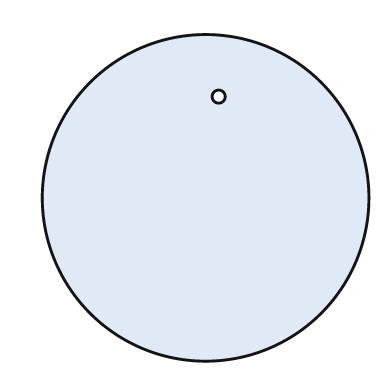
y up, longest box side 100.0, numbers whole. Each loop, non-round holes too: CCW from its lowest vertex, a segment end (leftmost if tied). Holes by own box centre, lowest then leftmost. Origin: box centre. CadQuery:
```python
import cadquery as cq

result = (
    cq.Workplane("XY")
    .moveTo(0.0, 0.0)
    .circle(50.0)
    .moveTo(4.0, 31.0)
    .circle(2.0)
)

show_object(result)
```